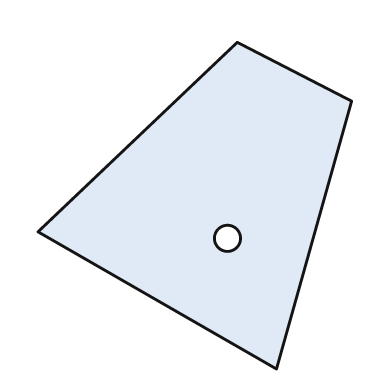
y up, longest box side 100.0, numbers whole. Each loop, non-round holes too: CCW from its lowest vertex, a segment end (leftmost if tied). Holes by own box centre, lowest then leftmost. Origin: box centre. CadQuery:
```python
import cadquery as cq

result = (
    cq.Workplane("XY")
    .moveTo(25.0, -50.0)
    .lineTo(48.0, 32.0)
    .lineTo(13.0, 50.0)
    .lineTo(-48.0, -8.0)
    .close()
    .moveTo(10.0, -10.0)
    .circle(4.0)
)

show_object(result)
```